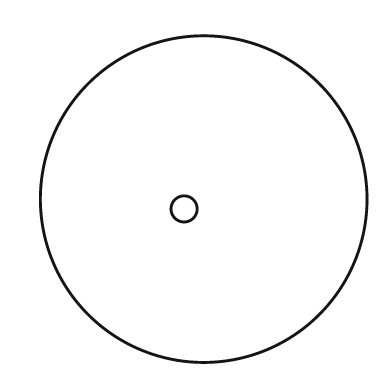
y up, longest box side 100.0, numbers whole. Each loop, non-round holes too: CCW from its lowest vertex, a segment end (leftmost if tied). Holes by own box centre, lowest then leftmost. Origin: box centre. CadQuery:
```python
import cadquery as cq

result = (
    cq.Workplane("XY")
    .moveTo(0.0, 0.0)
    .circle(50.0)
    .moveTo(-6.0, -3.0)
    .circle(4.0)
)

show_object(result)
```